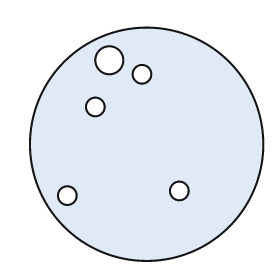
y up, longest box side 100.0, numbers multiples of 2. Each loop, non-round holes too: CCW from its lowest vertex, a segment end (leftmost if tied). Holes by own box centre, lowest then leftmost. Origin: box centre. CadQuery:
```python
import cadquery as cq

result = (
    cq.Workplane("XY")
    .moveTo(0.0, 0.0)
    .circle(50.0)
    .moveTo(-34.0, -22.0)
    .circle(4.0)
    .moveTo(14.0, -20.0)
    .circle(4.0)
    .moveTo(-22.0, 16.0)
    .circle(4.0)
    .moveTo(-2.0, 30.0)
    .circle(4.0)
    .moveTo(-16.0, 36.0)
    .circle(6.0)
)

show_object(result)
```